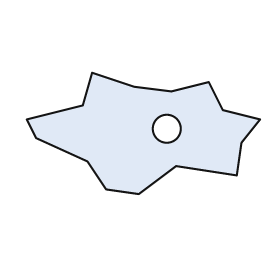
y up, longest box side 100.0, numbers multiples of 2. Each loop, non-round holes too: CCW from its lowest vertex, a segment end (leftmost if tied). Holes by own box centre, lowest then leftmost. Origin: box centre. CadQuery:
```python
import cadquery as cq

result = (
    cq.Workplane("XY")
    .moveTo(-2.0, -26.0)
    .lineTo(14.0, -14.0)
    .lineTo(40.0, -18.0)
    .lineTo(42.0, -4.0)
    .lineTo(50.0, 6.0)
    .lineTo(34.0, 10.0)
    .lineTo(28.0, 22.0)
    .lineTo(12.0, 18.0)
    .lineTo(-4.0, 20.0)
    .lineTo(-22.0, 26.0)
    .lineTo(-26.0, 12.0)
    .lineTo(-50.0, 6.0)
    .lineTo(-46.0, -2.0)
    .lineTo(-24.0, -12.0)
    .lineTo(-16.0, -24.0)
    .close()
    .moveTo(10.0, 2.0)
    .circle(6.0)
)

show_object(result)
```